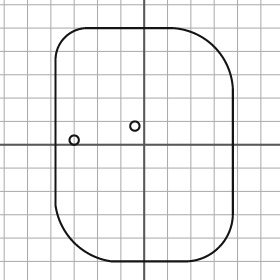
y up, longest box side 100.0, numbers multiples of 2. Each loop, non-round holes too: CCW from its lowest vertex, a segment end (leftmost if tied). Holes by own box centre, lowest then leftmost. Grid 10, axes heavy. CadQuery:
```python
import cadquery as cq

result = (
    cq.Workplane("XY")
    .moveTo(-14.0, -50.0)
    .lineTo(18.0, -50.0)
    .threePointArc((32.0, -44.0), (38.0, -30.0))
    .lineTo(38.0, 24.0)
    .threePointArc((30.0, 42.0), (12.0, 50.0))
    .lineTo(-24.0, 50.0)
    .threePointArc((-34.0, 46.0), (-38.0, 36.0))
    .lineTo(-38.0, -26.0)
    .threePointArc((-30.0, -42.0), (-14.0, -50.0))
    .close()
    .moveTo(-30.0, 2.0)
    .circle(2.0)
    .moveTo(-4.0, 8.0)
    .circle(2.0)
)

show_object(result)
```